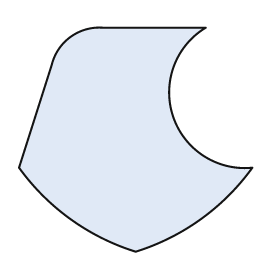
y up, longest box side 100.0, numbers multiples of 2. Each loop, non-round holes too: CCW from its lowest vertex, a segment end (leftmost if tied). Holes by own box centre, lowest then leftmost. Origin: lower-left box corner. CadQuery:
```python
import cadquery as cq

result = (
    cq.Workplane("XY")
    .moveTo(50.0, 0.0)
    .threePointArc((78.0, 14.0), (100.0, 36.0))
    .threePointArc((66.0, 58.0), (80.0, 96.0))
    .lineTo(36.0, 96.0)
    .threePointArc((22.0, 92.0), (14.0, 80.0))
    .lineTo(0.0, 36.0)
    .threePointArc((22.0, 14.0), (50.0, 0.0))
    .close()
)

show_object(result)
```